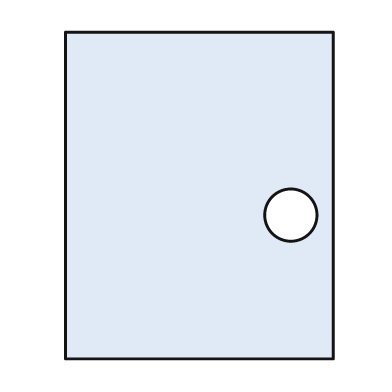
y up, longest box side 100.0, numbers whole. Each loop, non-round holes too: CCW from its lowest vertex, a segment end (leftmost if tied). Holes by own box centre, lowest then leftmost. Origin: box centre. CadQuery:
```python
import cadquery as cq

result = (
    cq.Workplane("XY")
    .moveTo(-41.0, -50.0)
    .lineTo(41.0, -50.0)
    .lineTo(41.0, 50.0)
    .lineTo(-41.0, 50.0)
    .close()
    .moveTo(28.0, -6.0)
    .circle(8.0)
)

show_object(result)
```